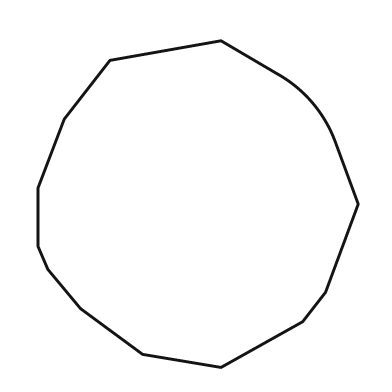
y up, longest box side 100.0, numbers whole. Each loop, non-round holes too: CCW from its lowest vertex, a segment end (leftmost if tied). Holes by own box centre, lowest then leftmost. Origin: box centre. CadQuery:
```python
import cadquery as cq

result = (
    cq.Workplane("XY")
    .moveTo(7.0, -50.0)
    .lineTo(32.0, -36.0)
    .lineTo(39.0, -27.0)
    .lineTo(49.0, 0.0)
    .lineTo(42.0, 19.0)
    .threePointArc((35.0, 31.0), (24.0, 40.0))
    .lineTo(7.0, 50.0)
    .lineTo(-27.0, 44.0)
    .lineTo(-41.0, 26.0)
    .lineTo(-49.0, 5.0)
    .lineTo(-49.0, -13.0)
    .lineTo(-46.0, -20.0)
    .lineTo(-36.0, -32.0)
    .lineTo(-17.0, -46.0)
    .close()
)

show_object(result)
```